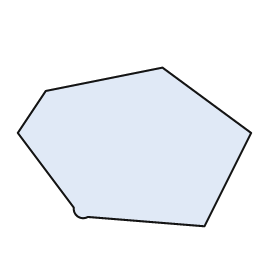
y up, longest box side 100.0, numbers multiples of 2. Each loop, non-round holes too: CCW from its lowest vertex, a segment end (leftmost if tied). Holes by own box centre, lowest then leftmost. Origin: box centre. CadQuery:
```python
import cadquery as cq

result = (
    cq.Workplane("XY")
    .moveTo(30.0, -34.0)
    .lineTo(50.0, 6.0)
    .lineTo(12.0, 34.0)
    .lineTo(-38.0, 24.0)
    .lineTo(-50.0, 6.0)
    .lineTo(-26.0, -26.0)
    .threePointArc((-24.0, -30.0), (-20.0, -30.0))
    .close()
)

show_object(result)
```